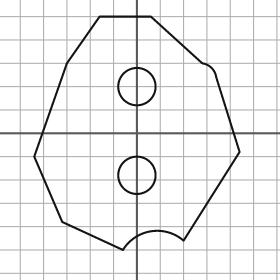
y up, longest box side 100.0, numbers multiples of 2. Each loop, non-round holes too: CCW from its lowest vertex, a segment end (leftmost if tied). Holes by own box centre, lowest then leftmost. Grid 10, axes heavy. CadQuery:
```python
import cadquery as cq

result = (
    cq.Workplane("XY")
    .moveTo(-6.0, -50.0)
    .threePointArc((6.0, -42.0), (20.0, -46.0))
    .lineTo(44.0, -8.0)
    .lineTo(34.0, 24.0)
    .threePointArc((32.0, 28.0), (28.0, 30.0))
    .lineTo(6.0, 50.0)
    .lineTo(-16.0, 50.0)
    .lineTo(-30.0, 30.0)
    .lineTo(-44.0, -10.0)
    .lineTo(-32.0, -38.0)
    .close()
    .moveTo(0.0, -18.0)
    .circle(8.0)
    .moveTo(0.0, 20.0)
    .circle(8.0)
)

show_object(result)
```